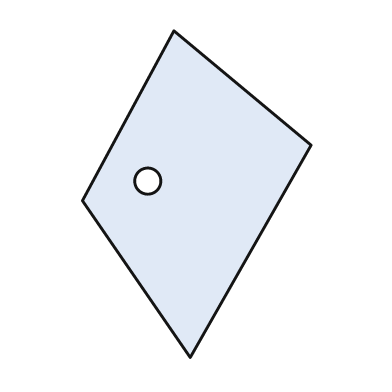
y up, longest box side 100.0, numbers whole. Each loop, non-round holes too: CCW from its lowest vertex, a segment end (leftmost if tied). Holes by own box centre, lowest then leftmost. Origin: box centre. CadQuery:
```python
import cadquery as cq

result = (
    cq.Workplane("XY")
    .moveTo(-2.0, -50.0)
    .lineTo(35.0, 15.0)
    .lineTo(-7.0, 50.0)
    .lineTo(-35.0, -2.0)
    .close()
    .moveTo(-15.0, 4.0)
    .circle(4.0)
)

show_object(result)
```